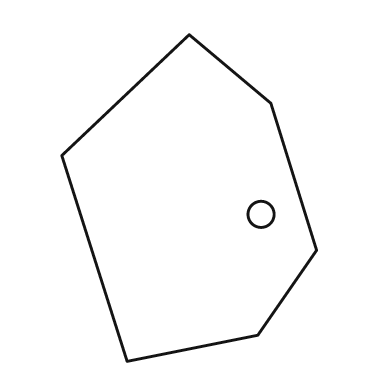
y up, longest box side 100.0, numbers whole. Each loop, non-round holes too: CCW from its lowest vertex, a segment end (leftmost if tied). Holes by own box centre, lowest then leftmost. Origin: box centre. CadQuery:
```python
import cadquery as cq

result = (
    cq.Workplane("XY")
    .moveTo(-19.0, -50.0)
    .lineTo(21.0, -42.0)
    .lineTo(39.0, -16.0)
    .lineTo(25.0, 29.0)
    .lineTo(0.0, 50.0)
    .lineTo(-39.0, 13.0)
    .close()
    .moveTo(22.0, -5.0)
    .circle(4.0)
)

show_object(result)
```